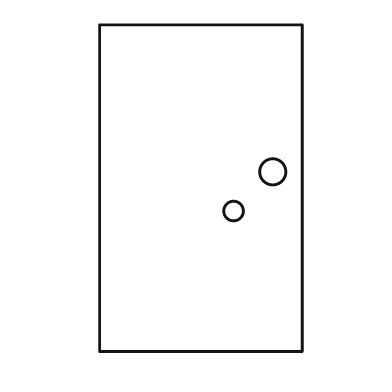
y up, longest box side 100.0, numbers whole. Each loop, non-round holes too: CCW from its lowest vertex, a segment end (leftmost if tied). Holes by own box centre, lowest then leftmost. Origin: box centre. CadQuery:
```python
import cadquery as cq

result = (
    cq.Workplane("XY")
    .moveTo(-31.0, -50.0)
    .lineTo(31.0, -50.0)
    .lineTo(31.0, 50.0)
    .lineTo(-31.0, 50.0)
    .close()
    .moveTo(10.0, -7.0)
    .circle(3.0)
    .moveTo(22.0, 5.0)
    .circle(4.0)
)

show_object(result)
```